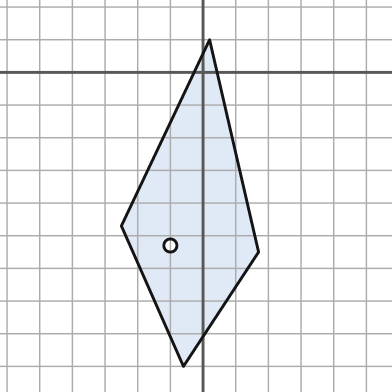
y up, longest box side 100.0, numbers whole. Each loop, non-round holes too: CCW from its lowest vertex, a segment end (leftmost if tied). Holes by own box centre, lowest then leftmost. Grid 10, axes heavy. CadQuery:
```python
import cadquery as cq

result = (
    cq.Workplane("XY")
    .moveTo(-6.0, -90.0)
    .lineTo(17.0, -55.0)
    .lineTo(2.0, 10.0)
    .lineTo(-25.0, -47.0)
    .close()
    .moveTo(-10.0, -53.0)
    .circle(2.0)
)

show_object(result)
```